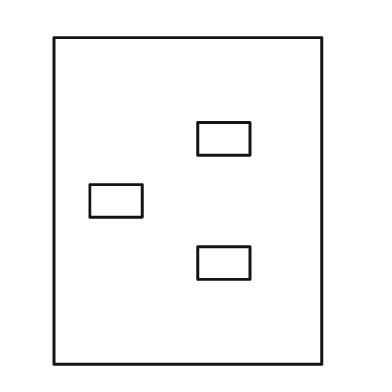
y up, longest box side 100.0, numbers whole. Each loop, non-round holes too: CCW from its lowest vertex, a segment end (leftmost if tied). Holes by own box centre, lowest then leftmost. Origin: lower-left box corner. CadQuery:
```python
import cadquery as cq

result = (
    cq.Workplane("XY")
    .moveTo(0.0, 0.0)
    .lineTo(82.0, 0.0)
    .lineTo(82.0, 100.0)
    .lineTo(0.0, 100.0)
    .close()
    .moveTo(44.0, 26.0)
    .lineTo(60.0, 26.0)
    .lineTo(60.0, 36.0)
    .lineTo(44.0, 36.0)
    .close()
    .moveTo(11.0, 45.0)
    .lineTo(27.0, 45.0)
    .lineTo(27.0, 55.0)
    .lineTo(11.0, 55.0)
    .close()
    .moveTo(44.0, 64.0)
    .lineTo(60.0, 64.0)
    .lineTo(60.0, 74.0)
    .lineTo(44.0, 74.0)
    .close()
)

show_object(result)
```